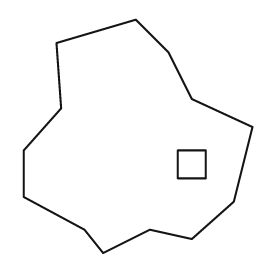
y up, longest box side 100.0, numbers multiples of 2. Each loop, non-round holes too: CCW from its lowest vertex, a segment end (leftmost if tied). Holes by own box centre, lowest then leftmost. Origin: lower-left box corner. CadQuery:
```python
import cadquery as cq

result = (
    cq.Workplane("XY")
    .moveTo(34.0, 0.0)
    .lineTo(54.0, 10.0)
    .lineTo(72.0, 6.0)
    .lineTo(90.0, 22.0)
    .lineTo(98.0, 54.0)
    .lineTo(72.0, 66.0)
    .lineTo(62.0, 86.0)
    .lineTo(48.0, 100.0)
    .lineTo(14.0, 90.0)
    .lineTo(16.0, 62.0)
    .lineTo(0.0, 44.0)
    .lineTo(0.0, 24.0)
    .lineTo(26.0, 10.0)
    .close()
    .moveTo(66.0, 32.0)
    .lineTo(78.0, 32.0)
    .lineTo(78.0, 44.0)
    .lineTo(66.0, 44.0)
    .close()
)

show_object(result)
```